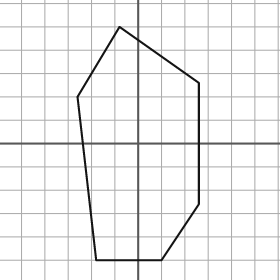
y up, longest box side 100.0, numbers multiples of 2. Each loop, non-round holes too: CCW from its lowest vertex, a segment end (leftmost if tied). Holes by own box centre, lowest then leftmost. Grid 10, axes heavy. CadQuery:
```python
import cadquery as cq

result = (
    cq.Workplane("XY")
    .moveTo(-18.0, -50.0)
    .lineTo(10.0, -50.0)
    .lineTo(26.0, -26.0)
    .lineTo(26.0, 26.0)
    .lineTo(-8.0, 50.0)
    .lineTo(-26.0, 20.0)
    .close()
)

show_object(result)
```